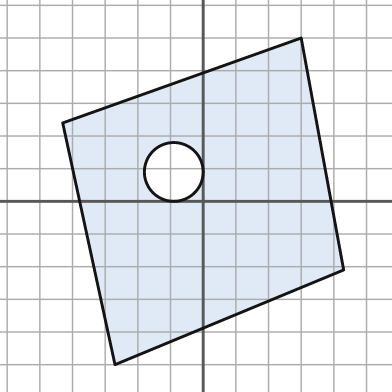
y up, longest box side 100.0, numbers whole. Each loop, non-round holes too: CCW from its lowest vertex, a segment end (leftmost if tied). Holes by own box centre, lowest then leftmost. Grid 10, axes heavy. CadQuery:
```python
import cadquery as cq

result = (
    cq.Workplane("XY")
    .moveTo(-27.0, -50.0)
    .lineTo(43.0, -21.0)
    .lineTo(30.0, 50.0)
    .lineTo(-43.0, 24.0)
    .close()
    .moveTo(-9.0, 9.0)
    .circle(9.0)
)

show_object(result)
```